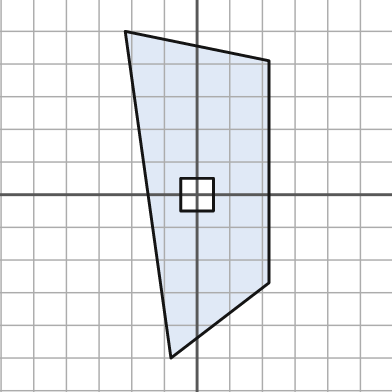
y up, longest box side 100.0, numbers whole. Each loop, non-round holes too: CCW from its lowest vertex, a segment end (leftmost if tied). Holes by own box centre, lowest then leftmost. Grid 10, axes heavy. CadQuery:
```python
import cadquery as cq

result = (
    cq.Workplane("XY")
    .moveTo(-8.0, -50.0)
    .lineTo(22.0, -27.0)
    .lineTo(22.0, 41.0)
    .lineTo(-22.0, 50.0)
    .close()
    .moveTo(-5.0, -5.0)
    .lineTo(5.0, -5.0)
    .lineTo(5.0, 5.0)
    .lineTo(-5.0, 5.0)
    .close()
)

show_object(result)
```